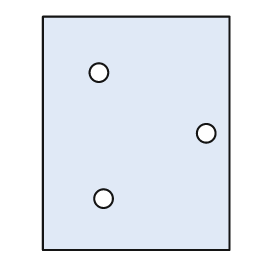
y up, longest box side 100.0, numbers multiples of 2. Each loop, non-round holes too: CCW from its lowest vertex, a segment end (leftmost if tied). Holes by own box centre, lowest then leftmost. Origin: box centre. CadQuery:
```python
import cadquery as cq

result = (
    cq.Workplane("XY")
    .moveTo(-40.0, -50.0)
    .lineTo(40.0, -50.0)
    .lineTo(40.0, 50.0)
    .lineTo(-40.0, 50.0)
    .close()
    .moveTo(-14.0, -28.0)
    .circle(4.0)
    .moveTo(30.0, 0.0)
    .circle(4.0)
    .moveTo(-16.0, 26.0)
    .circle(4.0)
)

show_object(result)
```